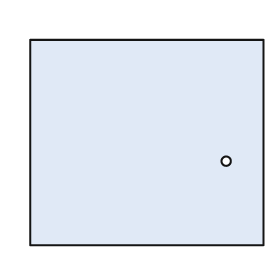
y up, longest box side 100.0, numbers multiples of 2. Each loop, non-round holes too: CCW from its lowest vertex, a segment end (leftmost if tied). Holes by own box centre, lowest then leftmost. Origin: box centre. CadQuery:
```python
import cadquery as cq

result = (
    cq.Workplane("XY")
    .moveTo(-50.0, -44.0)
    .lineTo(50.0, -44.0)
    .lineTo(50.0, 44.0)
    .lineTo(-50.0, 44.0)
    .close()
    .moveTo(34.0, -8.0)
    .circle(2.0)
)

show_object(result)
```